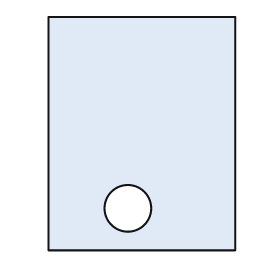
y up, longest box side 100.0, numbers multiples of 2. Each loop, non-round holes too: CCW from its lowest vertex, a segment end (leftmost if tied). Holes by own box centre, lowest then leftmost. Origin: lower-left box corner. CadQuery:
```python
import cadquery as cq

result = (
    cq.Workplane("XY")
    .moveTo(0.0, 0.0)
    .lineTo(80.0, 0.0)
    .lineTo(80.0, 100.0)
    .lineTo(0.0, 100.0)
    .close()
    .moveTo(34.0, 18.0)
    .circle(10.0)
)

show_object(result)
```